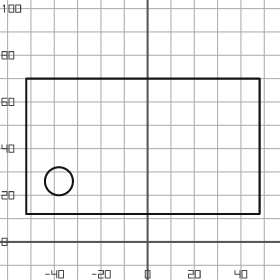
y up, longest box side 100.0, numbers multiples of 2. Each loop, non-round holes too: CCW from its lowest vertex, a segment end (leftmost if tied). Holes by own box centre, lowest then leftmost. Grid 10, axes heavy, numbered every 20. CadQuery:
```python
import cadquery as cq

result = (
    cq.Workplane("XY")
    .moveTo(-52.0, 12.0)
    .lineTo(48.0, 12.0)
    .lineTo(48.0, 70.0)
    .lineTo(-52.0, 70.0)
    .close()
    .moveTo(-38.0, 26.0)
    .circle(6.0)
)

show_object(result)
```